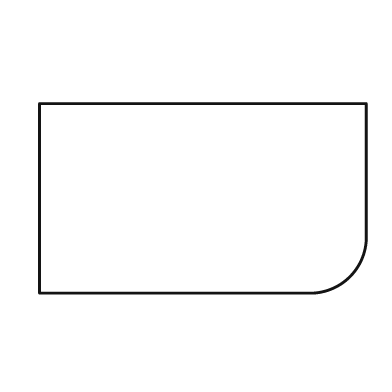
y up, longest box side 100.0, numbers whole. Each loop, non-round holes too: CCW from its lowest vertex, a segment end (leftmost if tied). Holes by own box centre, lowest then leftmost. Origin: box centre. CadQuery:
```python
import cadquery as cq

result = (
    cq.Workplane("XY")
    .moveTo(-50.0, -29.0)
    .lineTo(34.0, -29.0)
    .threePointArc((45.0, -24.0), (50.0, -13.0))
    .lineTo(50.0, 29.0)
    .lineTo(-50.0, 29.0)
    .close()
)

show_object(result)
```